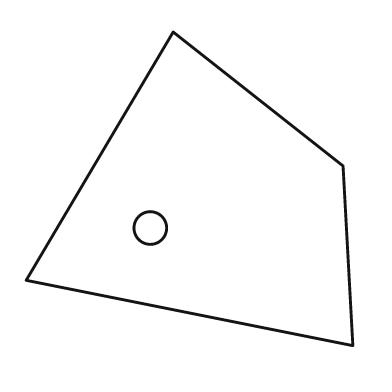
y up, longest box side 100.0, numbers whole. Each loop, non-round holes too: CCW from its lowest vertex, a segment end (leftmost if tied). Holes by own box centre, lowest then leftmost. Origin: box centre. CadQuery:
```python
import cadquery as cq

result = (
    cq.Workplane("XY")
    .moveTo(50.0, -48.0)
    .lineTo(47.0, 7.0)
    .lineTo(-5.0, 48.0)
    .lineTo(-50.0, -28.0)
    .close()
    .moveTo(-12.0, -12.0)
    .circle(5.0)
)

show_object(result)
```